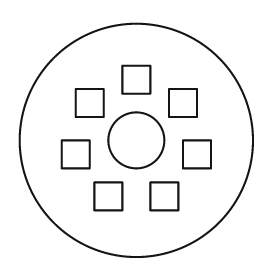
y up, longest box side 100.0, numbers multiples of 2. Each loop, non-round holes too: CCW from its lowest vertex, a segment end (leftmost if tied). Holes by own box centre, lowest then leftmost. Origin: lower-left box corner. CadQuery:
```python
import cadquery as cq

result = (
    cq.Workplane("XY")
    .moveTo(50.0, 50.0)
    .circle(50.0)
    .moveTo(32.0, 20.0)
    .lineTo(44.0, 20.0)
    .lineTo(44.0, 32.0)
    .lineTo(32.0, 32.0)
    .close()
    .moveTo(56.0, 20.0)
    .lineTo(68.0, 20.0)
    .lineTo(68.0, 32.0)
    .lineTo(56.0, 32.0)
    .close()
    .moveTo(18.0, 38.0)
    .lineTo(30.0, 38.0)
    .lineTo(30.0, 50.0)
    .lineTo(18.0, 50.0)
    .close()
    .moveTo(70.0, 38.0)
    .lineTo(82.0, 38.0)
    .lineTo(82.0, 50.0)
    .lineTo(70.0, 50.0)
    .close()
    .moveTo(50.0, 50.0)
    .circle(12.0)
    .moveTo(24.0, 60.0)
    .lineTo(36.0, 60.0)
    .lineTo(36.0, 72.0)
    .lineTo(24.0, 72.0)
    .close()
    .moveTo(64.0, 60.0)
    .lineTo(76.0, 60.0)
    .lineTo(76.0, 72.0)
    .lineTo(64.0, 72.0)
    .close()
    .moveTo(44.0, 70.0)
    .lineTo(56.0, 70.0)
    .lineTo(56.0, 82.0)
    .lineTo(44.0, 82.0)
    .close()
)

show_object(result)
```